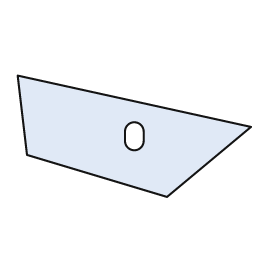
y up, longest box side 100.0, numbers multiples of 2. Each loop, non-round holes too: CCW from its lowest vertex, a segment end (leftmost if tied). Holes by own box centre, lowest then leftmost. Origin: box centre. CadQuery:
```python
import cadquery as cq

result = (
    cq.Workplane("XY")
    .moveTo(14.0, -26.0)
    .lineTo(50.0, 4.0)
    .lineTo(-50.0, 26.0)
    .lineTo(-46.0, -8.0)
    .close()
    .moveTo(-4.0, -2.0)
    .threePointArc((0.0, -6.0), (4.0, -2.0))
    .lineTo(4.0, 2.0)
    .threePointArc((0.0, 6.0), (-4.0, 2.0))
    .close()
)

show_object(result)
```